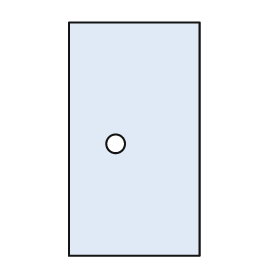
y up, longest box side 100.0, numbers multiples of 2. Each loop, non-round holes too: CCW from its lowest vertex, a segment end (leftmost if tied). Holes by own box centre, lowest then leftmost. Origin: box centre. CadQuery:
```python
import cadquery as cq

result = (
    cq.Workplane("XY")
    .moveTo(-28.0, -50.0)
    .lineTo(28.0, -50.0)
    .lineTo(28.0, 50.0)
    .lineTo(-28.0, 50.0)
    .close()
    .moveTo(-8.0, -2.0)
    .circle(4.0)
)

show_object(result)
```